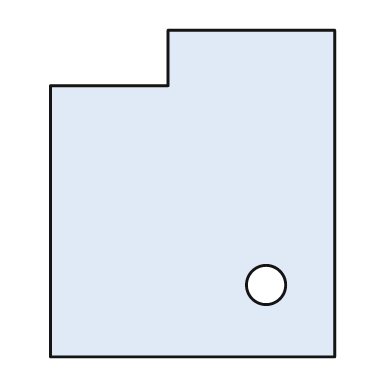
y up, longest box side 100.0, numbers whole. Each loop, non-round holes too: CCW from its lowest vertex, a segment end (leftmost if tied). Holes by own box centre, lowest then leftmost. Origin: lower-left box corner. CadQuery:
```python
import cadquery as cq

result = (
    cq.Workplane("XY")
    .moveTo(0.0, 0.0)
    .lineTo(87.0, 0.0)
    .lineTo(87.0, 100.0)
    .lineTo(36.0, 100.0)
    .lineTo(36.0, 83.0)
    .lineTo(0.0, 83.0)
    .close()
    .moveTo(66.0, 22.0)
    .circle(6.0)
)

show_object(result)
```